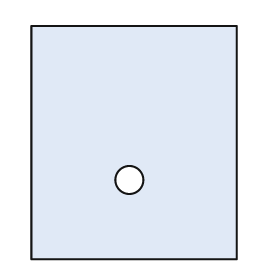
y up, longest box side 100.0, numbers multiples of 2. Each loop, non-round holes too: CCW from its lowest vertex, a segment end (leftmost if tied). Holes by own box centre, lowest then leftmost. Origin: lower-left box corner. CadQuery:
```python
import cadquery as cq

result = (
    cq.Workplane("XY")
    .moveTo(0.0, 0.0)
    .lineTo(88.0, 0.0)
    .lineTo(88.0, 100.0)
    .lineTo(0.0, 100.0)
    .close()
    .moveTo(42.0, 34.0)
    .circle(6.0)
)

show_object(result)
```